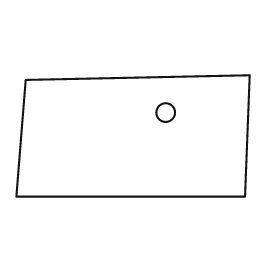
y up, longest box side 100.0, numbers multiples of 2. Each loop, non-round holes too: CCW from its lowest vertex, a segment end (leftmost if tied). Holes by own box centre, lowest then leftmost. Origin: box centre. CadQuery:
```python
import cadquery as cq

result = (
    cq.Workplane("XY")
    .moveTo(-50.0, -26.0)
    .lineTo(48.0, -26.0)
    .lineTo(50.0, 26.0)
    .lineTo(-46.0, 24.0)
    .close()
    .moveTo(14.0, 10.0)
    .circle(4.0)
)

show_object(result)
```